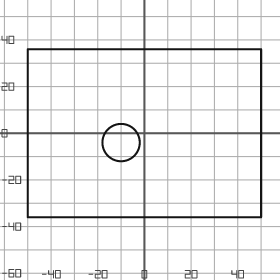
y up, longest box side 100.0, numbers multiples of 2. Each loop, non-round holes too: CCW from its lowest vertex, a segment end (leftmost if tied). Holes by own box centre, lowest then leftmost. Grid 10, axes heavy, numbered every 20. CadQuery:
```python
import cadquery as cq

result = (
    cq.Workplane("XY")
    .moveTo(-50.0, -36.0)
    .lineTo(50.0, -36.0)
    .lineTo(50.0, 36.0)
    .lineTo(-50.0, 36.0)
    .close()
    .moveTo(-10.0, -4.0)
    .circle(8.0)
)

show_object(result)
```